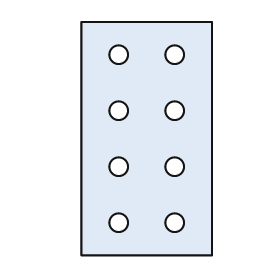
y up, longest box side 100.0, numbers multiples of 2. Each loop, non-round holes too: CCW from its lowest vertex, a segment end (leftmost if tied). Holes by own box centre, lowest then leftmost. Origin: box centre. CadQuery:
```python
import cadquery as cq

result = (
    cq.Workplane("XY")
    .moveTo(-28.0, -50.0)
    .lineTo(28.0, -50.0)
    .lineTo(28.0, 50.0)
    .lineTo(-28.0, 50.0)
    .close()
    .moveTo(-12.0, -36.0)
    .circle(4.0)
    .moveTo(12.0, -36.0)
    .circle(4.0)
    .moveTo(-12.0, -12.0)
    .circle(4.0)
    .moveTo(12.0, -12.0)
    .circle(4.0)
    .moveTo(-12.0, 12.0)
    .circle(4.0)
    .moveTo(12.0, 12.0)
    .circle(4.0)
    .moveTo(-12.0, 36.0)
    .circle(4.0)
    .moveTo(12.0, 36.0)
    .circle(4.0)
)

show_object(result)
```